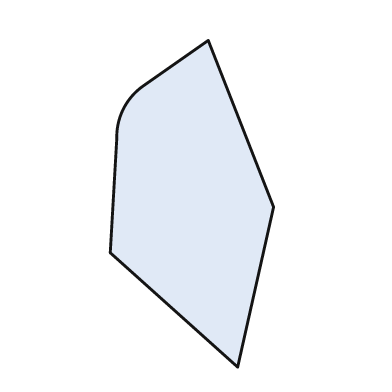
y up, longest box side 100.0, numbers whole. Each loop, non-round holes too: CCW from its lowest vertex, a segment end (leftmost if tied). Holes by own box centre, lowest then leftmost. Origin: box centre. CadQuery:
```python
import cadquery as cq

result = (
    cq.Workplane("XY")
    .moveTo(14.0, -50.0)
    .lineTo(25.0, -1.0)
    .lineTo(5.0, 50.0)
    .lineTo(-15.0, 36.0)
    .threePointArc((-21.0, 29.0), (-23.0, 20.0))
    .lineTo(-25.0, -15.0)
    .close()
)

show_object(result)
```